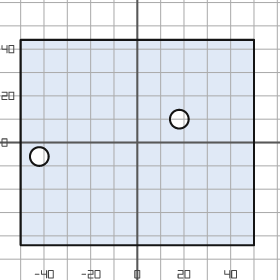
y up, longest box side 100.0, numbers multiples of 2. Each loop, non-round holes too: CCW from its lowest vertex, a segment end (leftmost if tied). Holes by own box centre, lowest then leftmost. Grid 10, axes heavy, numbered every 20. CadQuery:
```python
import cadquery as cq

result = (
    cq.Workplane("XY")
    .moveTo(-50.0, -44.0)
    .lineTo(50.0, -44.0)
    .lineTo(50.0, 44.0)
    .lineTo(-50.0, 44.0)
    .close()
    .moveTo(-42.0, -6.0)
    .circle(4.0)
    .moveTo(18.0, 10.0)
    .circle(4.0)
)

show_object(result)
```